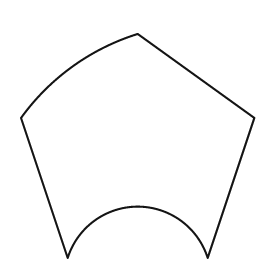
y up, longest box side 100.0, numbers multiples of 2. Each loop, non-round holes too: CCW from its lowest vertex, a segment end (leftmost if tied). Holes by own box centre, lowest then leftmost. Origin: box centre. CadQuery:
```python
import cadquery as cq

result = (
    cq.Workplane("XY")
    .moveTo(-30.0, -48.0)
    .threePointArc((0.0, -26.0), (30.0, -48.0))
    .lineTo(50.0, 12.0)
    .lineTo(0.0, 48.0)
    .threePointArc((-28.0, 34.0), (-50.0, 12.0))
    .close()
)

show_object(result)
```